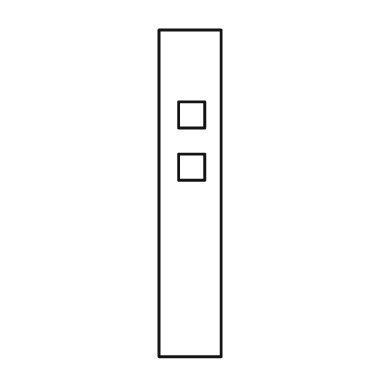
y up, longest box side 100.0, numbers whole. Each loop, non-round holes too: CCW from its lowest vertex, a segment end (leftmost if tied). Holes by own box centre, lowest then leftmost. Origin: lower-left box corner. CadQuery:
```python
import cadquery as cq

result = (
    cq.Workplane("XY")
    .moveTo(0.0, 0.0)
    .lineTo(19.0, 0.0)
    .lineTo(19.0, 100.0)
    .lineTo(0.0, 100.0)
    .close()
    .moveTo(6.0, 54.0)
    .lineTo(14.0, 54.0)
    .lineTo(14.0, 62.0)
    .lineTo(6.0, 62.0)
    .close()
    .moveTo(6.0, 70.0)
    .lineTo(14.0, 70.0)
    .lineTo(14.0, 78.0)
    .lineTo(6.0, 78.0)
    .close()
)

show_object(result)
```